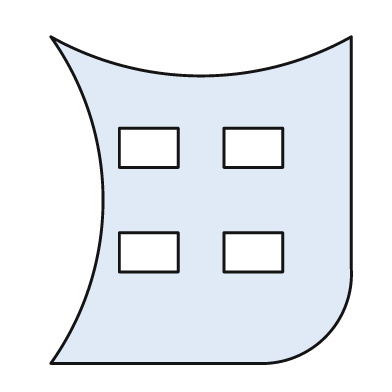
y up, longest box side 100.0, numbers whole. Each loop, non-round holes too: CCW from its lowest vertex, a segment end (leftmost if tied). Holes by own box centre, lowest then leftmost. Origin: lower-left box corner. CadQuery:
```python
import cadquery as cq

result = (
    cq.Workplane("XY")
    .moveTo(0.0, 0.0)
    .lineTo(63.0, 0.0)
    .threePointArc((84.0, 8.0), (92.0, 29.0))
    .lineTo(92.0, 100.0)
    .threePointArc((46.0, 88.0), (0.0, 100.0))
    .threePointArc((16.0, 50.0), (0.0, 0.0))
    .close()
    .moveTo(21.0, 28.0)
    .lineTo(39.0, 28.0)
    .lineTo(39.0, 40.0)
    .lineTo(21.0, 40.0)
    .close()
    .moveTo(53.0, 28.0)
    .lineTo(71.0, 28.0)
    .lineTo(71.0, 40.0)
    .lineTo(53.0, 40.0)
    .close()
    .moveTo(21.0, 60.0)
    .lineTo(39.0, 60.0)
    .lineTo(39.0, 72.0)
    .lineTo(21.0, 72.0)
    .close()
    .moveTo(53.0, 60.0)
    .lineTo(71.0, 60.0)
    .lineTo(71.0, 72.0)
    .lineTo(53.0, 72.0)
    .close()
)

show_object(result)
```